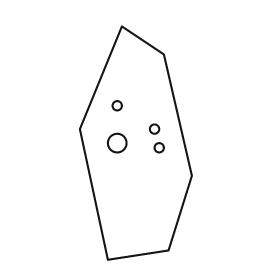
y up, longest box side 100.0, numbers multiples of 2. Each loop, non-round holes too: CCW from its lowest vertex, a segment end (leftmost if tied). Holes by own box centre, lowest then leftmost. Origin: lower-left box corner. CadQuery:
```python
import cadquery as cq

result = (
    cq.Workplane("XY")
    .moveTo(12.0, 0.0)
    .lineTo(38.0, 4.0)
    .lineTo(48.0, 36.0)
    .lineTo(36.0, 88.0)
    .lineTo(18.0, 100.0)
    .lineTo(0.0, 56.0)
    .close()
    .moveTo(34.0, 48.0)
    .circle(2.0)
    .moveTo(16.0, 50.0)
    .circle(4.0)
    .moveTo(32.0, 56.0)
    .circle(2.0)
    .moveTo(16.0, 66.0)
    .circle(2.0)
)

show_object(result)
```